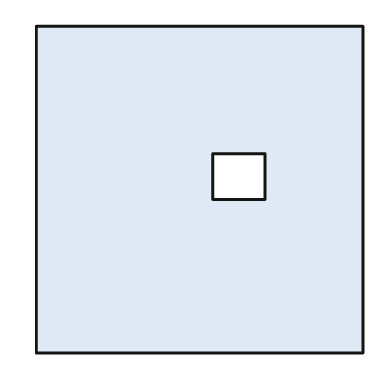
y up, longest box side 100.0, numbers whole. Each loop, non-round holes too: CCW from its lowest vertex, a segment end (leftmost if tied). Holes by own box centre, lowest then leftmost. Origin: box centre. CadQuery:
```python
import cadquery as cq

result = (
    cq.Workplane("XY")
    .moveTo(-50.0, -50.0)
    .lineTo(50.0, -50.0)
    .lineTo(50.0, 50.0)
    .lineTo(-50.0, 50.0)
    .close()
    .moveTo(4.0, -3.0)
    .lineTo(20.0, -3.0)
    .lineTo(20.0, 11.0)
    .lineTo(4.0, 11.0)
    .close()
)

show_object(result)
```